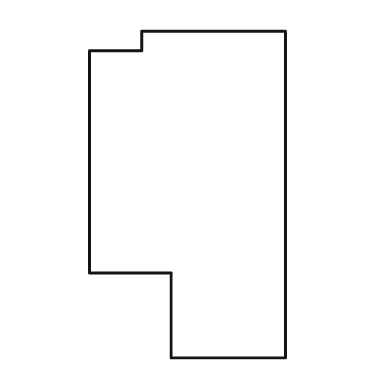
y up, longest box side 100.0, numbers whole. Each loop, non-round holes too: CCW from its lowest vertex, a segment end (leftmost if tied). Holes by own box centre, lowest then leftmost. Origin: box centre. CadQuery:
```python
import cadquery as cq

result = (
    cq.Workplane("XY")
    .moveTo(-5.0, -50.0)
    .lineTo(30.0, -50.0)
    .lineTo(30.0, 50.0)
    .lineTo(-14.0, 50.0)
    .lineTo(-14.0, 44.0)
    .lineTo(-30.0, 44.0)
    .lineTo(-30.0, -24.0)
    .lineTo(-5.0, -24.0)
    .close()
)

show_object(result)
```